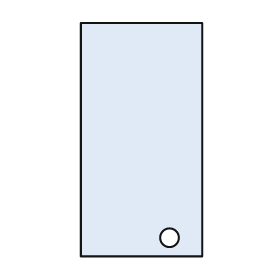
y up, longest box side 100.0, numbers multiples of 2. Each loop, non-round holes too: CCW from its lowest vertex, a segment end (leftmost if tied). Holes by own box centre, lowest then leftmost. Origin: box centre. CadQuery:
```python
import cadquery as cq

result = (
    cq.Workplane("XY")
    .moveTo(-26.0, -50.0)
    .lineTo(26.0, -50.0)
    .lineTo(26.0, 50.0)
    .lineTo(-26.0, 50.0)
    .close()
    .moveTo(12.0, -42.0)
    .circle(4.0)
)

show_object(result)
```